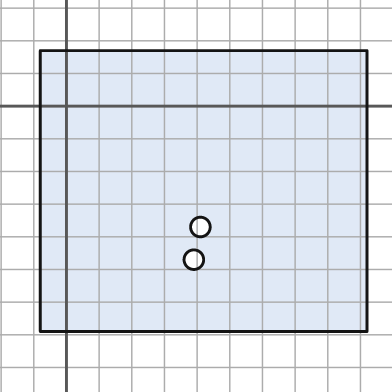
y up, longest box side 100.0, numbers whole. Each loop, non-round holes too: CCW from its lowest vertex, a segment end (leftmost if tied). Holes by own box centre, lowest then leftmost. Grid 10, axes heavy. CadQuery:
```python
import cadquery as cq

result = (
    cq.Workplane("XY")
    .moveTo(-8.0, -69.0)
    .lineTo(92.0, -69.0)
    .lineTo(92.0, 17.0)
    .lineTo(-8.0, 17.0)
    .close()
    .moveTo(39.0, -47.0)
    .circle(3.0)
    .moveTo(41.0, -37.0)
    .circle(3.0)
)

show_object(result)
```